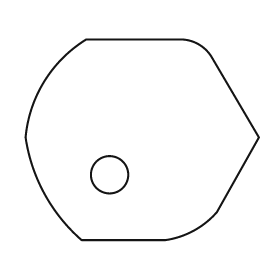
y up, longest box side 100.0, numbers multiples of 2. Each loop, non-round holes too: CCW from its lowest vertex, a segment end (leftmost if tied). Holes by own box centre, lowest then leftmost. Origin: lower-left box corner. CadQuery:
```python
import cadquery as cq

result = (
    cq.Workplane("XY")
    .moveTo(24.0, 0.0)
    .lineTo(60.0, 0.0)
    .threePointArc((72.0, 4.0), (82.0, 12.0))
    .lineTo(100.0, 44.0)
    .lineTo(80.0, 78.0)
    .threePointArc((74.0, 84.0), (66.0, 86.0))
    .lineTo(26.0, 86.0)
    .threePointArc((8.0, 68.0), (0.0, 44.0))
    .threePointArc((8.0, 20.0), (24.0, 0.0))
    .close()
    .moveTo(36.0, 28.0)
    .circle(8.0)
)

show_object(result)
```